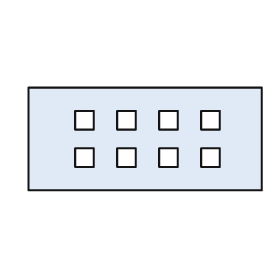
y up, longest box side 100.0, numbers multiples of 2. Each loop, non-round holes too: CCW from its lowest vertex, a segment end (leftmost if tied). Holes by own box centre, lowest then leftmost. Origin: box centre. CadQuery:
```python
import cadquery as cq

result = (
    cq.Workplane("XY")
    .moveTo(-50.0, -22.0)
    .lineTo(50.0, -22.0)
    .lineTo(50.0, 22.0)
    .lineTo(-50.0, 22.0)
    .close()
    .moveTo(-30.0, -12.0)
    .lineTo(-22.0, -12.0)
    .lineTo(-22.0, -4.0)
    .lineTo(-30.0, -4.0)
    .close()
    .moveTo(-12.0, -12.0)
    .lineTo(-4.0, -12.0)
    .lineTo(-4.0, -4.0)
    .lineTo(-12.0, -4.0)
    .close()
    .moveTo(6.0, -12.0)
    .lineTo(14.0, -12.0)
    .lineTo(14.0, -4.0)
    .lineTo(6.0, -4.0)
    .close()
    .moveTo(24.0, -12.0)
    .lineTo(32.0, -12.0)
    .lineTo(32.0, -4.0)
    .lineTo(24.0, -4.0)
    .close()
    .moveTo(-30.0, 4.0)
    .lineTo(-22.0, 4.0)
    .lineTo(-22.0, 12.0)
    .lineTo(-30.0, 12.0)
    .close()
    .moveTo(-12.0, 4.0)
    .lineTo(-4.0, 4.0)
    .lineTo(-4.0, 12.0)
    .lineTo(-12.0, 12.0)
    .close()
    .moveTo(6.0, 4.0)
    .lineTo(14.0, 4.0)
    .lineTo(14.0, 12.0)
    .lineTo(6.0, 12.0)
    .close()
    .moveTo(24.0, 4.0)
    .lineTo(32.0, 4.0)
    .lineTo(32.0, 12.0)
    .lineTo(24.0, 12.0)
    .close()
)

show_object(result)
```